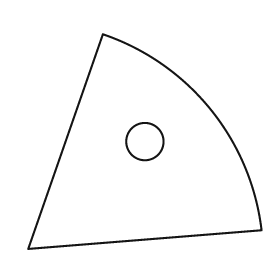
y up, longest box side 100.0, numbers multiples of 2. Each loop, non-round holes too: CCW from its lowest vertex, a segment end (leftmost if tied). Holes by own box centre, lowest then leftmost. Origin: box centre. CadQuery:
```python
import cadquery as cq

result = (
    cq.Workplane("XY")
    .moveTo(-50.0, -46.0)
    .lineTo(50.0, -38.0)
    .threePointArc((28.0, 14.0), (-18.0, 46.0))
    .close()
    .moveTo(0.0, 0.0)
    .circle(8.0)
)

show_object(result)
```